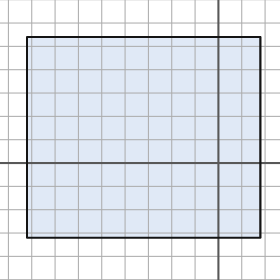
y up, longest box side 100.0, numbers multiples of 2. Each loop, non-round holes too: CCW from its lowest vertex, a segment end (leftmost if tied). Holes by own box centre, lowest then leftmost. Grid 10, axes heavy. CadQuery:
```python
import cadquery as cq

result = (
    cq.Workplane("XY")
    .moveTo(-82.0, -32.0)
    .lineTo(18.0, -32.0)
    .lineTo(18.0, 54.0)
    .lineTo(-82.0, 54.0)
    .close()
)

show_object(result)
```